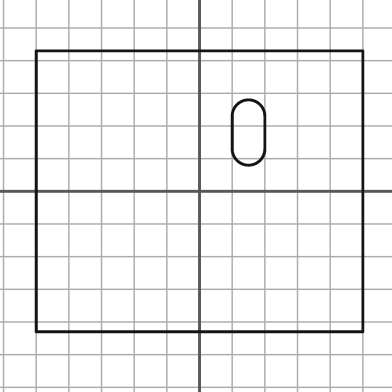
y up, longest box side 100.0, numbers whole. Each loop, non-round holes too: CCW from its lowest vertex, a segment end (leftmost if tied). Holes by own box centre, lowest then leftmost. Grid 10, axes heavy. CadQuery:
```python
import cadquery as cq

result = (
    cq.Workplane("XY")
    .moveTo(-50.0, -43.0)
    .lineTo(50.0, -43.0)
    .lineTo(50.0, 43.0)
    .lineTo(-50.0, 43.0)
    .close()
    .moveTo(10.0, 13.0)
    .threePointArc((15.0, 8.0), (20.0, 13.0))
    .lineTo(20.0, 23.0)
    .threePointArc((15.0, 28.0), (10.0, 23.0))
    .close()
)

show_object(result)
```